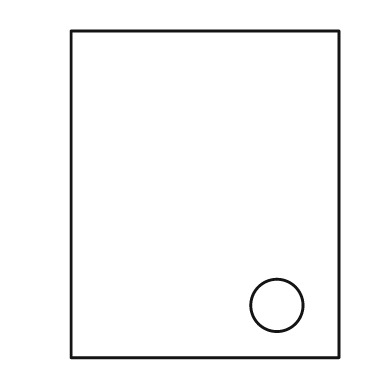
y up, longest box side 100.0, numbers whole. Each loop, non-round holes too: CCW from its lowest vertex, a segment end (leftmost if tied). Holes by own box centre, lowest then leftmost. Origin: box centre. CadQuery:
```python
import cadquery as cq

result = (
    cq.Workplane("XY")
    .moveTo(-41.0, -50.0)
    .lineTo(41.0, -50.0)
    .lineTo(41.0, 50.0)
    .lineTo(-41.0, 50.0)
    .close()
    .moveTo(22.0, -34.0)
    .circle(8.0)
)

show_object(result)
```